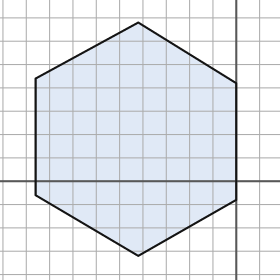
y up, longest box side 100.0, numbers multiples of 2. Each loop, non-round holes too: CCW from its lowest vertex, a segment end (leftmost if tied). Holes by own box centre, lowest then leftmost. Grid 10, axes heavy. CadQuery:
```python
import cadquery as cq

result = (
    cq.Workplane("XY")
    .moveTo(-42.0, -32.0)
    .lineTo(0.0, -8.0)
    .lineTo(0.0, 42.0)
    .lineTo(-42.0, 68.0)
    .lineTo(-86.0, 44.0)
    .lineTo(-86.0, -6.0)
    .close()
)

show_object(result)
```